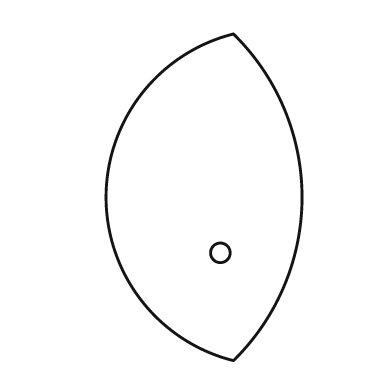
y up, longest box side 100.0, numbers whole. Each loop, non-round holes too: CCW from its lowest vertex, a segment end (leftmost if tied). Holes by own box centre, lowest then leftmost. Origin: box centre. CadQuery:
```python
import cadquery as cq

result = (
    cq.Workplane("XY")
    .moveTo(9.0, -50.0)
    .threePointArc((30.0, 0.0), (9.0, 50.0))
    .threePointArc((-30.0, 0.0), (9.0, -50.0))
    .close()
    .moveTo(5.0, -17.0)
    .circle(3.0)
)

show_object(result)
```